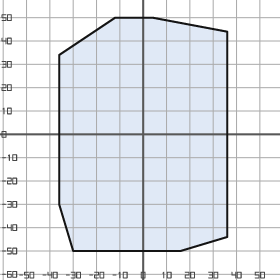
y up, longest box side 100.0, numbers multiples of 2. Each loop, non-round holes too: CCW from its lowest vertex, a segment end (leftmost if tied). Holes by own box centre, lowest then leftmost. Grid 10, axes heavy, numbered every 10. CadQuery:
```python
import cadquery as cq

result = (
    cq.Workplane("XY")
    .moveTo(-30.0, -50.0)
    .lineTo(16.0, -50.0)
    .lineTo(36.0, -44.0)
    .lineTo(36.0, 44.0)
    .lineTo(4.0, 50.0)
    .lineTo(-12.0, 50.0)
    .lineTo(-36.0, 34.0)
    .lineTo(-36.0, -30.0)
    .close()
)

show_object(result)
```